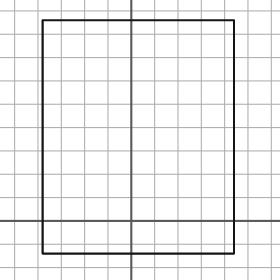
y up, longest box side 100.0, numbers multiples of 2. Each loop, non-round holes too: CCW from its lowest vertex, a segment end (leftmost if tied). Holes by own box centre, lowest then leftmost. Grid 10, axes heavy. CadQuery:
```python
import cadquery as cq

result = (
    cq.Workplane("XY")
    .moveTo(-38.0, -14.0)
    .lineTo(44.0, -14.0)
    .lineTo(44.0, 86.0)
    .lineTo(-38.0, 86.0)
    .close()
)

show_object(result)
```